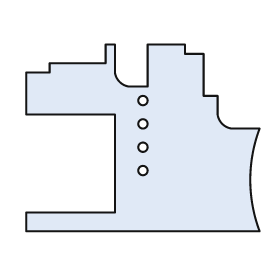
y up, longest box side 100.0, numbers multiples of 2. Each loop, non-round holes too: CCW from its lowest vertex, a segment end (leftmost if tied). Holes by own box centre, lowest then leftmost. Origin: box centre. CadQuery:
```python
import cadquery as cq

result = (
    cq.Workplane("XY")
    .moveTo(-50.0, -40.0)
    .lineTo(50.0, -40.0)
    .threePointArc((46.0, -18.0), (50.0, 4.0))
    .lineTo(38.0, 4.0)
    .threePointArc((34.0, 6.0), (32.0, 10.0))
    .lineTo(32.0, 18.0)
    .lineTo(26.0, 18.0)
    .lineTo(26.0, 36.0)
    .lineTo(18.0, 36.0)
    .lineTo(18.0, 40.0)
    .lineTo(2.0, 40.0)
    .lineTo(2.0, 22.0)
    .lineTo(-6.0, 22.0)
    .threePointArc((-10.0, 24.0), (-12.0, 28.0))
    .lineTo(-12.0, 40.0)
    .lineTo(-16.0, 40.0)
    .lineTo(-16.0, 32.0)
    .lineTo(-40.0, 32.0)
    .lineTo(-40.0, 28.0)
    .lineTo(-50.0, 28.0)
    .lineTo(-50.0, 10.0)
    .lineTo(-12.0, 10.0)
    .lineTo(-12.0, -32.0)
    .lineTo(-50.0, -32.0)
    .close()
    .moveTo(0.0, -14.0)
    .circle(2.0)
    .moveTo(0.0, -4.0)
    .circle(2.0)
    .moveTo(0.0, 6.0)
    .circle(2.0)
    .moveTo(0.0, 16.0)
    .circle(2.0)
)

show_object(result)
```